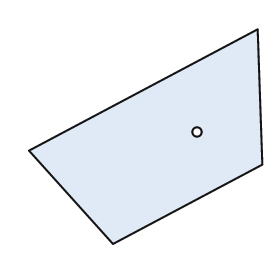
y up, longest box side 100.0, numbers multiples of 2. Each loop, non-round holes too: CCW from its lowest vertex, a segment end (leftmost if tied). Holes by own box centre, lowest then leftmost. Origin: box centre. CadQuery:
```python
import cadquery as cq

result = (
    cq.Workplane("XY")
    .moveTo(-14.0, -46.0)
    .lineTo(50.0, -12.0)
    .lineTo(48.0, 46.0)
    .lineTo(-50.0, -6.0)
    .close()
    .moveTo(22.0, 2.0)
    .circle(2.0)
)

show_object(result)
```